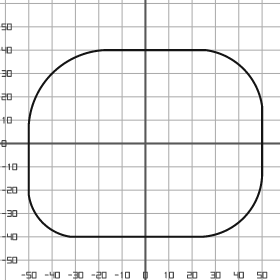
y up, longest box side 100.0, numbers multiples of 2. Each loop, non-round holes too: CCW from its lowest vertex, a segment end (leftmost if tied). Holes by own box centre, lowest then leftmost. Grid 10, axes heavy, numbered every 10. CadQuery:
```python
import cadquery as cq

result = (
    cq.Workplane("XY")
    .moveTo(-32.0, -40.0)
    .lineTo(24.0, -40.0)
    .threePointArc((42.0, -32.0), (50.0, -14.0))
    .lineTo(50.0, 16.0)
    .threePointArc((42.0, 32.0), (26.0, 40.0))
    .lineTo(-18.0, 40.0)
    .threePointArc((-40.0, 30.0), (-50.0, 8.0))
    .lineTo(-50.0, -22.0)
    .threePointArc((-44.0, -34.0), (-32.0, -40.0))
    .close()
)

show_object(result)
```